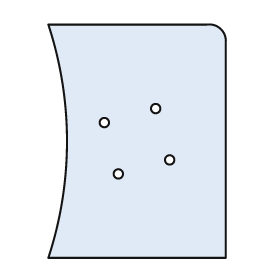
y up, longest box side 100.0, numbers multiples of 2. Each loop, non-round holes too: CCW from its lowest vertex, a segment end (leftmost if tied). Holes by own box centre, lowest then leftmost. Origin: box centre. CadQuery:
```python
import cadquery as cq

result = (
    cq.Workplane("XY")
    .moveTo(-38.0, -50.0)
    .lineTo(38.0, -50.0)
    .lineTo(38.0, 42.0)
    .threePointArc((36.0, 48.0), (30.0, 50.0))
    .lineTo(-38.0, 50.0)
    .threePointArc((-30.0, 0.0), (-38.0, -50.0))
    .close()
    .moveTo(-8.0, -14.0)
    .circle(2.0)
    .moveTo(14.0, -8.0)
    .circle(2.0)
    .moveTo(-14.0, 8.0)
    .circle(2.0)
    .moveTo(8.0, 14.0)
    .circle(2.0)
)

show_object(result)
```